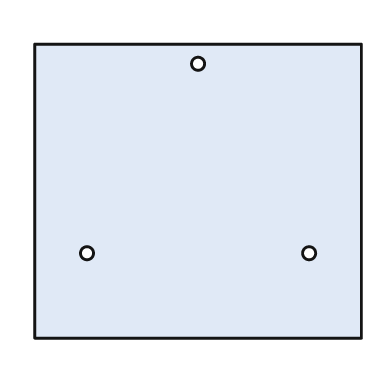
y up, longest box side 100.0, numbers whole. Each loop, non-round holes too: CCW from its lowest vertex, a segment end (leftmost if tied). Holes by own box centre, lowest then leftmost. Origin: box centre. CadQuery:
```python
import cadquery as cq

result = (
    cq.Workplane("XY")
    .moveTo(-50.0, -45.0)
    .lineTo(50.0, -45.0)
    .lineTo(50.0, 45.0)
    .lineTo(-50.0, 45.0)
    .close()
    .moveTo(-34.0, -19.0)
    .circle(2.0)
    .moveTo(34.0, -19.0)
    .circle(2.0)
    .moveTo(0.0, 39.0)
    .circle(2.0)
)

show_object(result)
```